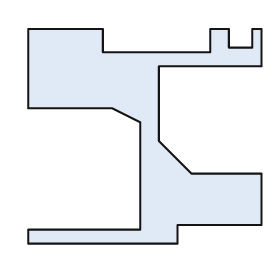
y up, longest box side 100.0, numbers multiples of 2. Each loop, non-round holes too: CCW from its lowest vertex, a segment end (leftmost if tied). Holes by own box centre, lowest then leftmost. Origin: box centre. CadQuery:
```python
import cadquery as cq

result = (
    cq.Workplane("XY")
    .moveTo(-50.0, -46.0)
    .lineTo(14.0, -46.0)
    .lineTo(14.0, -38.0)
    .lineTo(50.0, -38.0)
    .lineTo(50.0, -16.0)
    .lineTo(20.0, -16.0)
    .lineTo(6.0, -2.0)
    .lineTo(6.0, 30.0)
    .lineTo(50.0, 30.0)
    .lineTo(50.0, 46.0)
    .lineTo(46.0, 46.0)
    .lineTo(46.0, 38.0)
    .lineTo(36.0, 38.0)
    .lineTo(36.0, 46.0)
    .lineTo(28.0, 46.0)
    .lineTo(28.0, 36.0)
    .lineTo(-18.0, 36.0)
    .lineTo(-18.0, 46.0)
    .lineTo(-50.0, 46.0)
    .lineTo(-50.0, 12.0)
    .lineTo(-14.0, 12.0)
    .lineTo(-2.0, 6.0)
    .lineTo(-2.0, -40.0)
    .lineTo(-50.0, -40.0)
    .close()
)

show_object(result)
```